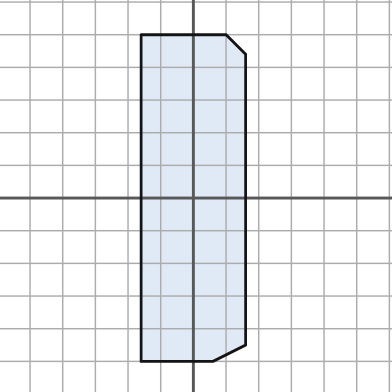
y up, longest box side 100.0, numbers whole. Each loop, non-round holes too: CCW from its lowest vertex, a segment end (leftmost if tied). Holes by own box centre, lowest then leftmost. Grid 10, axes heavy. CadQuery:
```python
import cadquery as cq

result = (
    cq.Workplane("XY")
    .moveTo(-16.0, -50.0)
    .lineTo(6.0, -50.0)
    .lineTo(16.0, -45.0)
    .lineTo(16.0, 44.0)
    .lineTo(10.0, 50.0)
    .lineTo(-16.0, 50.0)
    .close()
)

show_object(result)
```